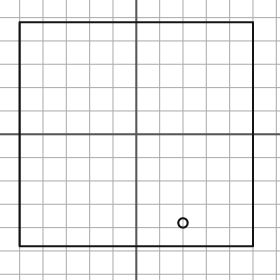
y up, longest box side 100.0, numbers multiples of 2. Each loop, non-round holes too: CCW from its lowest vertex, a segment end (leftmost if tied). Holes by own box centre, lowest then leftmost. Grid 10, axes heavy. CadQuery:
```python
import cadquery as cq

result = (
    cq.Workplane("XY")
    .moveTo(-50.0, -48.0)
    .lineTo(50.0, -48.0)
    .lineTo(50.0, 48.0)
    .lineTo(-50.0, 48.0)
    .close()
    .moveTo(20.0, -38.0)
    .circle(2.0)
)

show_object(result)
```